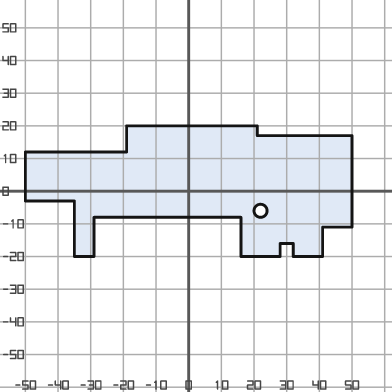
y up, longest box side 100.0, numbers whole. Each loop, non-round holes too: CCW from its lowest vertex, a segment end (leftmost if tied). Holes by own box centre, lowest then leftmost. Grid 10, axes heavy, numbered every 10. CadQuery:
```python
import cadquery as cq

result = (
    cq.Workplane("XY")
    .moveTo(-35.0, -20.0)
    .lineTo(-29.0, -20.0)
    .lineTo(-29.0, -8.0)
    .lineTo(16.0, -8.0)
    .lineTo(16.0, -20.0)
    .lineTo(28.0, -20.0)
    .lineTo(28.0, -16.0)
    .lineTo(32.0, -16.0)
    .lineTo(32.0, -20.0)
    .lineTo(41.0, -20.0)
    .lineTo(41.0, -11.0)
    .lineTo(50.0, -11.0)
    .lineTo(50.0, 17.0)
    .lineTo(21.0, 17.0)
    .lineTo(21.0, 20.0)
    .lineTo(-19.0, 20.0)
    .lineTo(-19.0, 12.0)
    .lineTo(-50.0, 12.0)
    .lineTo(-50.0, -3.0)
    .lineTo(-35.0, -3.0)
    .close()
    .moveTo(22.0, -6.0)
    .circle(2.0)
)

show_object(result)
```